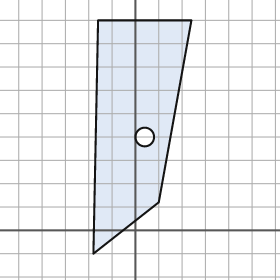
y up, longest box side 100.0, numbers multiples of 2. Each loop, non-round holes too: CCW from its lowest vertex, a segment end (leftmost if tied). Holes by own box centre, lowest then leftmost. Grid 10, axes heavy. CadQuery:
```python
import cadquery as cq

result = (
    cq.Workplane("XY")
    .moveTo(-18.0, -10.0)
    .lineTo(10.0, 12.0)
    .lineTo(24.0, 90.0)
    .lineTo(-16.0, 90.0)
    .close()
    .moveTo(4.0, 40.0)
    .circle(4.0)
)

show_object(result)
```